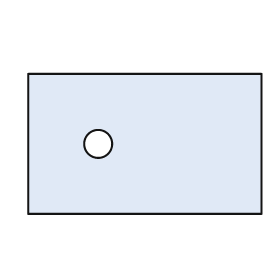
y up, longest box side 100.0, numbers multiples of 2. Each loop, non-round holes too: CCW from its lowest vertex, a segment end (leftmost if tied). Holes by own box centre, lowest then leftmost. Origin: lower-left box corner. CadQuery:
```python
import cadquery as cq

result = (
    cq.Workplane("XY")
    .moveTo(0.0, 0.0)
    .lineTo(100.0, 0.0)
    .lineTo(100.0, 60.0)
    .lineTo(0.0, 60.0)
    .close()
    .moveTo(30.0, 30.0)
    .circle(6.0)
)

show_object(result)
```